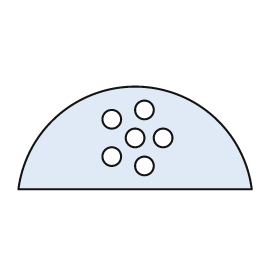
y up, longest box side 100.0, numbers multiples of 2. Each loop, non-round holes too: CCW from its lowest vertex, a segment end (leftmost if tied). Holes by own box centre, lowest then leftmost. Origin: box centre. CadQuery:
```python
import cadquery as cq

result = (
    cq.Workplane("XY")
    .moveTo(-50.0, -22.0)
    .lineTo(50.0, -22.0)
    .threePointArc((0.0, 22.0), (-50.0, -22.0))
    .close()
    .moveTo(4.0, -12.0)
    .circle(4.0)
    .moveTo(-10.0, -8.0)
    .circle(4.0)
    .moveTo(0.0, 0.0)
    .circle(4.0)
    .moveTo(12.0, 0.0)
    .circle(4.0)
    .moveTo(-10.0, 8.0)
    .circle(4.0)
    .moveTo(4.0, 12.0)
    .circle(4.0)
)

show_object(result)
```